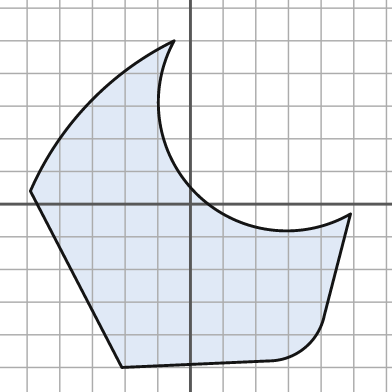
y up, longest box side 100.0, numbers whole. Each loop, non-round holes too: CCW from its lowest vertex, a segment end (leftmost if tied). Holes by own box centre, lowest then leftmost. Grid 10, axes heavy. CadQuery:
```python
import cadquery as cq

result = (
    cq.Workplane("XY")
    .moveTo(-21.0, -50.0)
    .lineTo(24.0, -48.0)
    .threePointArc((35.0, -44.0), (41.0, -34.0))
    .lineTo(49.0, -3.0)
    .threePointArc((2.0, 3.0), (-5.0, 50.0))
    .threePointArc((-31.0, 31.0), (-49.0, 4.0))
    .close()
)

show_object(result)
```